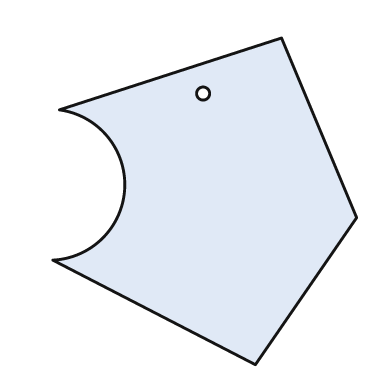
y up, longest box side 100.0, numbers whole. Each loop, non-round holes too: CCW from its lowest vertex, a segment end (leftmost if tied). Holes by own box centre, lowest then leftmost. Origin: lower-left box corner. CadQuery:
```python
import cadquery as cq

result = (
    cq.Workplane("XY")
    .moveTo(62.0, 0.0)
    .lineTo(93.0, 45.0)
    .lineTo(70.0, 100.0)
    .lineTo(2.0, 78.0)
    .threePointArc((22.0, 54.0), (0.0, 32.0))
    .close()
    .moveTo(46.0, 83.0)
    .circle(2.0)
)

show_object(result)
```